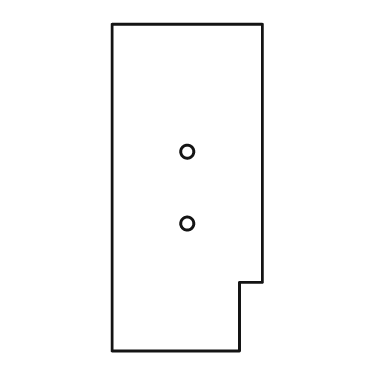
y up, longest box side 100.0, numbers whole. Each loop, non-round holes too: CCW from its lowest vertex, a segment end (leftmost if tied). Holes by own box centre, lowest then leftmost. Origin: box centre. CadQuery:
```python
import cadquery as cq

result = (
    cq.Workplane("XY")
    .moveTo(-23.0, -50.0)
    .lineTo(16.0, -50.0)
    .lineTo(16.0, -29.0)
    .lineTo(23.0, -29.0)
    .lineTo(23.0, 50.0)
    .lineTo(-23.0, 50.0)
    .close()
    .moveTo(0.0, -11.0)
    .circle(2.0)
    .moveTo(0.0, 11.0)
    .circle(2.0)
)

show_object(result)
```